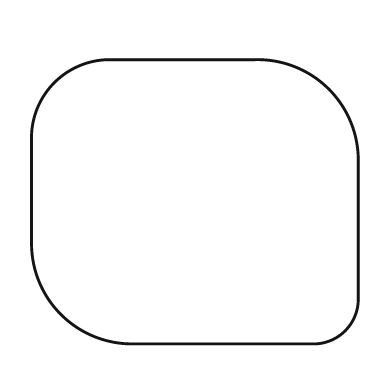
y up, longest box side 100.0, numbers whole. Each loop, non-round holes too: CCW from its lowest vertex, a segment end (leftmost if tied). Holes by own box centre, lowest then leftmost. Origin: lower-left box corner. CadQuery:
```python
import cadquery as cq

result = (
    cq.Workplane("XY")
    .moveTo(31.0, 0.0)
    .lineTo(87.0, 0.0)
    .threePointArc((96.0, 4.0), (100.0, 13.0))
    .lineTo(100.0, 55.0)
    .threePointArc((91.0, 78.0), (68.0, 87.0))
    .lineTo(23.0, 87.0)
    .threePointArc((7.0, 80.0), (0.0, 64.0))
    .lineTo(0.0, 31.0)
    .threePointArc((9.0, 9.0), (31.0, 0.0))
    .close()
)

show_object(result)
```